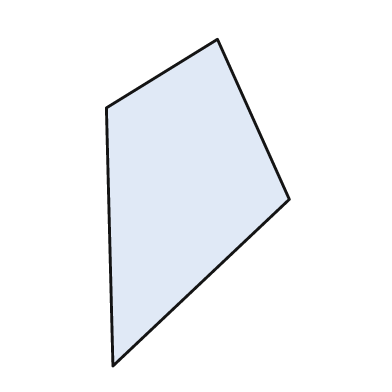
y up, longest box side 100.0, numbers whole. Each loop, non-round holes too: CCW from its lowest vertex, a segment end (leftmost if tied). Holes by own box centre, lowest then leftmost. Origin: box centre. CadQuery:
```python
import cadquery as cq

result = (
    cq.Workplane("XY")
    .moveTo(-26.0, -50.0)
    .lineTo(28.0, 1.0)
    .lineTo(6.0, 50.0)
    .lineTo(-28.0, 29.0)
    .close()
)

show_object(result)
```